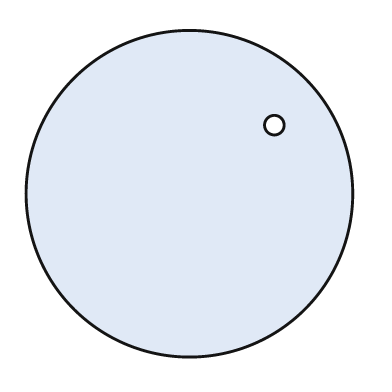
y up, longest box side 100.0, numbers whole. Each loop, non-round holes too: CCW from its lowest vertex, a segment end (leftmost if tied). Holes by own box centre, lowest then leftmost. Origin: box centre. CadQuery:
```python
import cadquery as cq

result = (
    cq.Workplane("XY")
    .moveTo(0.0, 0.0)
    .circle(50.0)
    .moveTo(26.0, 21.0)
    .circle(3.0)
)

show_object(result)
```